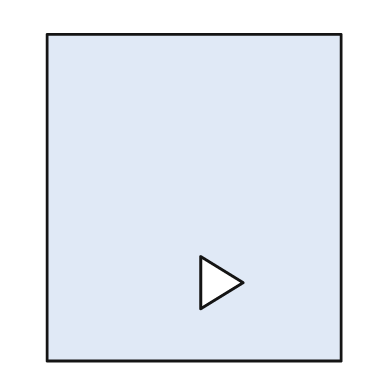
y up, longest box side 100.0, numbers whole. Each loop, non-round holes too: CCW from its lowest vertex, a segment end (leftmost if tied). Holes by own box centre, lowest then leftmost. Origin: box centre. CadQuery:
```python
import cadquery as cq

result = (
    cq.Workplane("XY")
    .moveTo(-45.0, -50.0)
    .lineTo(45.0, -50.0)
    .lineTo(45.0, 50.0)
    .lineTo(-45.0, 50.0)
    .close()
    .moveTo(2.0, -34.0)
    .lineTo(15.0, -26.0)
    .lineTo(2.0, -18.0)
    .close()
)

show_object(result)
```